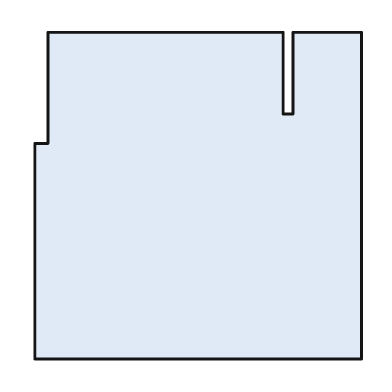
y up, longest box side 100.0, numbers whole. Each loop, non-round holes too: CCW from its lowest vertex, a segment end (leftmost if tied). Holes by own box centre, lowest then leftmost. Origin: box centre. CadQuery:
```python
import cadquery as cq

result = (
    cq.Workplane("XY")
    .moveTo(-50.0, -50.0)
    .lineTo(50.0, -50.0)
    .lineTo(50.0, 50.0)
    .lineTo(29.0, 50.0)
    .lineTo(29.0, 25.0)
    .lineTo(26.0, 25.0)
    .lineTo(26.0, 50.0)
    .lineTo(-46.0, 50.0)
    .lineTo(-46.0, 16.0)
    .lineTo(-50.0, 16.0)
    .close()
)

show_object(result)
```